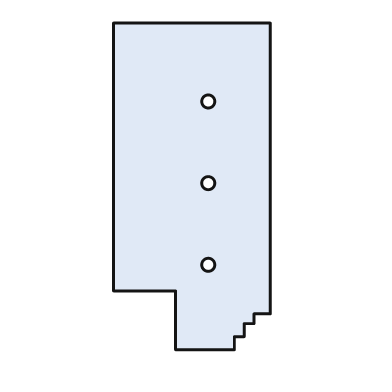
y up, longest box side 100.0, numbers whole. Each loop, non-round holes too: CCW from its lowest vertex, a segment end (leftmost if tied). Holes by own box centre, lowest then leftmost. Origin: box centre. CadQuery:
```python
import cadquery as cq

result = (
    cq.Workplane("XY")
    .moveTo(-5.0, -50.0)
    .lineTo(13.0, -50.0)
    .lineTo(13.0, -46.0)
    .lineTo(16.0, -46.0)
    .lineTo(16.0, -42.0)
    .lineTo(19.0, -42.0)
    .lineTo(19.0, -39.0)
    .lineTo(24.0, -39.0)
    .lineTo(24.0, 50.0)
    .lineTo(-24.0, 50.0)
    .lineTo(-24.0, -32.0)
    .lineTo(-5.0, -32.0)
    .close()
    .moveTo(5.0, -24.0)
    .circle(2.0)
    .moveTo(5.0, 1.0)
    .circle(2.0)
    .moveTo(5.0, 26.0)
    .circle(2.0)
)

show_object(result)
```